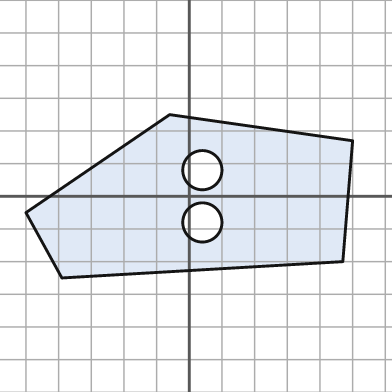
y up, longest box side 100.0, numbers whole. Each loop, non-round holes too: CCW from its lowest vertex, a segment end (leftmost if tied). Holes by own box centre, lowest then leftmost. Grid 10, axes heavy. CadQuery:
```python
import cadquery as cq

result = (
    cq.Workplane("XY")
    .moveTo(-39.0, -25.0)
    .lineTo(47.0, -20.0)
    .lineTo(50.0, 17.0)
    .lineTo(-6.0, 25.0)
    .lineTo(-50.0, -5.0)
    .close()
    .moveTo(4.0, -8.0)
    .circle(6.0)
    .moveTo(4.0, 8.0)
    .circle(6.0)
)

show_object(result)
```